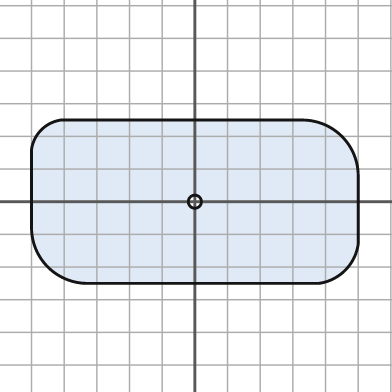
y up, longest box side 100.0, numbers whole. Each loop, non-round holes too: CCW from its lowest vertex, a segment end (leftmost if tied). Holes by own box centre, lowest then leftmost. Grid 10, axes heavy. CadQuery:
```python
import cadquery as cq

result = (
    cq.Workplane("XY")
    .moveTo(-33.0, -25.0)
    .lineTo(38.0, -25.0)
    .threePointArc((46.0, -21.0), (50.0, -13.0))
    .lineTo(50.0, 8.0)
    .threePointArc((45.0, 20.0), (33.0, 25.0))
    .lineTo(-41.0, 25.0)
    .threePointArc((-47.0, 22.0), (-50.0, 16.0))
    .lineTo(-50.0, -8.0)
    .threePointArc((-45.0, -20.0), (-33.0, -25.0))
    .close()
    .moveTo(0.0, 0.0)
    .circle(2.0)
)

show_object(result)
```